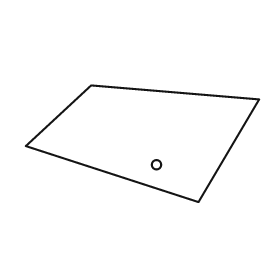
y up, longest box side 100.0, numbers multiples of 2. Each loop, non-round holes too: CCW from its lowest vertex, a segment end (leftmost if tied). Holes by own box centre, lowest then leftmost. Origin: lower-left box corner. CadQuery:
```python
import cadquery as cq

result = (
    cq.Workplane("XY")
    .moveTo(74.0, 0.0)
    .lineTo(100.0, 44.0)
    .lineTo(28.0, 50.0)
    .lineTo(0.0, 24.0)
    .close()
    .moveTo(56.0, 16.0)
    .circle(2.0)
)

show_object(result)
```